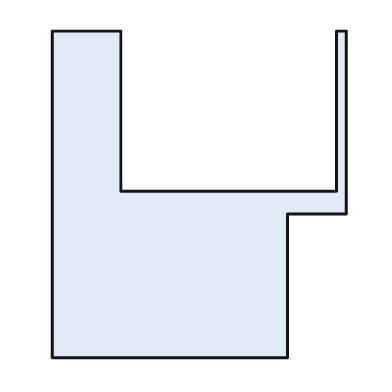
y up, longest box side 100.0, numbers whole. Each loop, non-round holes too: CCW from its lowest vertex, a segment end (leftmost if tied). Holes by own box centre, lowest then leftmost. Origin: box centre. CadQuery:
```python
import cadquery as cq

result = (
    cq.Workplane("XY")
    .moveTo(-45.0, -50.0)
    .lineTo(27.0, -50.0)
    .lineTo(27.0, -6.0)
    .lineTo(45.0, -6.0)
    .lineTo(45.0, 50.0)
    .lineTo(42.0, 50.0)
    .lineTo(42.0, 1.0)
    .lineTo(-24.0, 1.0)
    .lineTo(-24.0, 50.0)
    .lineTo(-45.0, 50.0)
    .close()
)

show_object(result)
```